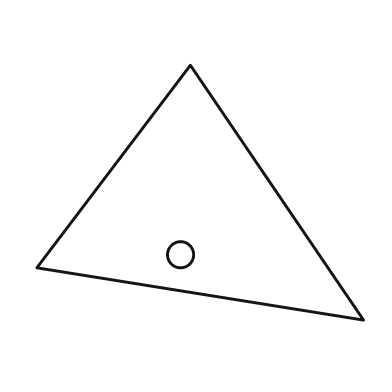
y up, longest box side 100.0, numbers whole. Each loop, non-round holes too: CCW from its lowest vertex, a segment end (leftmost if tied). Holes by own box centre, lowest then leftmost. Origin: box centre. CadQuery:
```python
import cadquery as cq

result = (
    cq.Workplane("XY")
    .moveTo(50.0, -39.0)
    .lineTo(-3.0, 39.0)
    .lineTo(-50.0, -23.0)
    .close()
    .moveTo(-6.0, -19.0)
    .circle(4.0)
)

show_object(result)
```